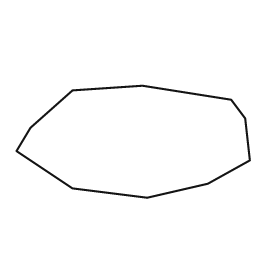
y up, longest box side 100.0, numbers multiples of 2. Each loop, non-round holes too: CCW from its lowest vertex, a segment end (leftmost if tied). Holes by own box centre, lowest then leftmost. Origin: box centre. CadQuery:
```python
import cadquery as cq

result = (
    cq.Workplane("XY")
    .moveTo(6.0, -24.0)
    .lineTo(32.0, -18.0)
    .lineTo(50.0, -8.0)
    .lineTo(48.0, 10.0)
    .lineTo(42.0, 18.0)
    .lineTo(4.0, 24.0)
    .lineTo(-26.0, 22.0)
    .lineTo(-44.0, 6.0)
    .lineTo(-50.0, -4.0)
    .lineTo(-26.0, -20.0)
    .close()
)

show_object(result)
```